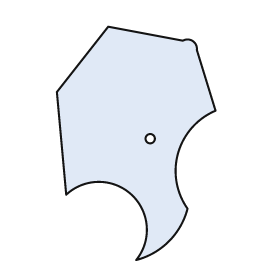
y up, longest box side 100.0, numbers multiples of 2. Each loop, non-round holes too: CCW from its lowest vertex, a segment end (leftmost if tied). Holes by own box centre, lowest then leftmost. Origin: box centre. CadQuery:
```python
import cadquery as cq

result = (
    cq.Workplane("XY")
    .moveTo(0.0, -50.0)
    .threePointArc((14.0, -42.0), (22.0, -28.0))
    .threePointArc((18.0, -4.0), (34.0, 14.0))
    .lineTo(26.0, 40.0)
    .threePointArc((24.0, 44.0), (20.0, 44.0))
    .lineTo(-12.0, 50.0)
    .lineTo(-34.0, 22.0)
    .lineTo(-30.0, -22.0)
    .threePointArc((-2.0, -22.0), (0.0, -50.0))
    .close()
    .moveTo(6.0, 2.0)
    .circle(2.0)
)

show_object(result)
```